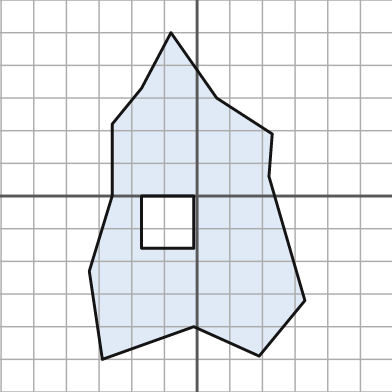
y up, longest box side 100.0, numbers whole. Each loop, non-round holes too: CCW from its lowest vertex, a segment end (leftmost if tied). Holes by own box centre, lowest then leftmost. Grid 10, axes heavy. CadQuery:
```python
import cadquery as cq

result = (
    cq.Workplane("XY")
    .moveTo(-29.0, -50.0)
    .lineTo(-1.0, -40.0)
    .lineTo(19.0, -49.0)
    .lineTo(33.0, -32.0)
    .lineTo(22.0, 6.0)
    .lineTo(23.0, 19.0)
    .lineTo(6.0, 30.0)
    .lineTo(-8.0, 50.0)
    .lineTo(-17.0, 33.0)
    .lineTo(-26.0, 22.0)
    .lineTo(-26.0, 0.0)
    .lineTo(-33.0, -23.0)
    .close()
    .moveTo(-17.0, -16.0)
    .lineTo(-1.0, -16.0)
    .lineTo(-1.0, 0.0)
    .lineTo(-17.0, 0.0)
    .close()
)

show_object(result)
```